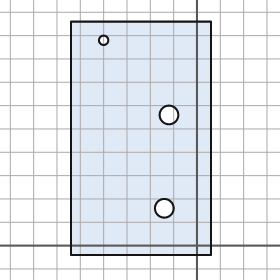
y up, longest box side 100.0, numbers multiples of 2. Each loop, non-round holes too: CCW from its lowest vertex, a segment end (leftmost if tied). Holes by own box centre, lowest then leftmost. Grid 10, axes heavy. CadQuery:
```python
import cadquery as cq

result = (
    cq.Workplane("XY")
    .moveTo(-54.0, -4.0)
    .lineTo(6.0, -4.0)
    .lineTo(6.0, 96.0)
    .lineTo(-54.0, 96.0)
    .close()
    .moveTo(-14.0, 16.0)
    .circle(4.0)
    .moveTo(-12.0, 56.0)
    .circle(4.0)
    .moveTo(-40.0, 88.0)
    .circle(2.0)
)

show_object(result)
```